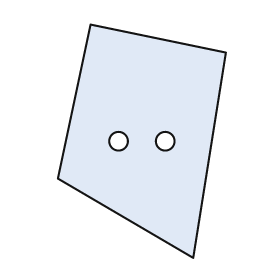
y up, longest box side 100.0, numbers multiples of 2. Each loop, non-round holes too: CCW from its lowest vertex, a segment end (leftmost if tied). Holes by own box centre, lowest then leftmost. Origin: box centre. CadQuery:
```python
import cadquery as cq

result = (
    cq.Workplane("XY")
    .moveTo(22.0, -50.0)
    .lineTo(36.0, 38.0)
    .lineTo(-22.0, 50.0)
    .lineTo(-36.0, -16.0)
    .close()
    .moveTo(-10.0, 0.0)
    .circle(4.0)
    .moveTo(10.0, 0.0)
    .circle(4.0)
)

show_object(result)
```